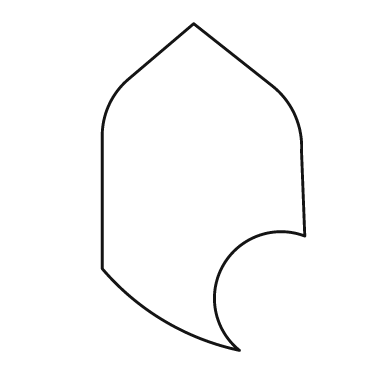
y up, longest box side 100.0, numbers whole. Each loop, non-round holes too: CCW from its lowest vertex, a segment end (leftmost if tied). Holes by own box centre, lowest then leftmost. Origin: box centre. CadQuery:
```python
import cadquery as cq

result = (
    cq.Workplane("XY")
    .moveTo(11.0, -50.0)
    .threePointArc((6.0, -24.0), (31.0, -15.0))
    .lineTo(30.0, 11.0)
    .threePointArc((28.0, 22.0), (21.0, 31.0))
    .lineTo(-3.0, 50.0)
    .lineTo(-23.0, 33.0)
    .threePointArc((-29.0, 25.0), (-31.0, 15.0))
    .lineTo(-31.0, -25.0)
    .threePointArc((-12.0, -41.0), (11.0, -50.0))
    .close()
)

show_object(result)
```